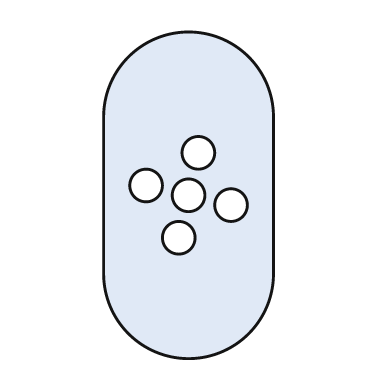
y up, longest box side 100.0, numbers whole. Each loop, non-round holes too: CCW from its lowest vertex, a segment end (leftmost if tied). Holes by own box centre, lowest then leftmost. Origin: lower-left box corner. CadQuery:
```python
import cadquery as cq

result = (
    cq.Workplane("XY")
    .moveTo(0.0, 26.0)
    .threePointArc((26.0, 0.0), (52.0, 26.0))
    .lineTo(52.0, 74.0)
    .threePointArc((26.0, 100.0), (0.0, 74.0))
    .close()
    .moveTo(23.0, 37.0)
    .circle(5.0)
    .moveTo(39.0, 47.0)
    .circle(5.0)
    .moveTo(26.0, 50.0)
    .circle(5.0)
    .moveTo(13.0, 53.0)
    .circle(5.0)
    .moveTo(29.0, 63.0)
    .circle(5.0)
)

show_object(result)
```